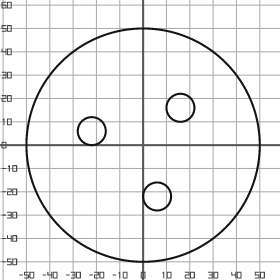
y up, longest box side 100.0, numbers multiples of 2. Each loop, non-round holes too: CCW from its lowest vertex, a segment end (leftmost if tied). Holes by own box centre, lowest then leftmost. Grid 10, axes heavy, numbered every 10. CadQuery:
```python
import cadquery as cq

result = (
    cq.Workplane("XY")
    .moveTo(0.0, 0.0)
    .circle(50.0)
    .moveTo(6.0, -22.0)
    .circle(6.0)
    .moveTo(-22.0, 6.0)
    .circle(6.0)
    .moveTo(16.0, 16.0)
    .circle(6.0)
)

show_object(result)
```